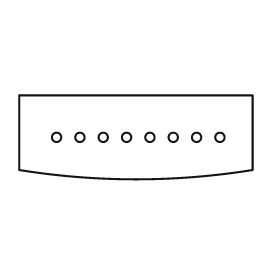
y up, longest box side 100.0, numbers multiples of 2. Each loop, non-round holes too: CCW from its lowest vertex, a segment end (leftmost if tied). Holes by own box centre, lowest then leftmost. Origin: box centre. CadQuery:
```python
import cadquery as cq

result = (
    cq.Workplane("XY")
    .moveTo(-50.0, -14.0)
    .threePointArc((0.0, -18.0), (50.0, -14.0))
    .lineTo(50.0, 18.0)
    .lineTo(-50.0, 18.0)
    .close()
    .moveTo(-34.0, 0.0)
    .circle(2.0)
    .moveTo(-24.0, 0.0)
    .circle(2.0)
    .moveTo(-14.0, 0.0)
    .circle(2.0)
    .moveTo(-4.0, 0.0)
    .circle(2.0)
    .moveTo(6.0, 0.0)
    .circle(2.0)
    .moveTo(16.0, 0.0)
    .circle(2.0)
    .moveTo(26.0, 0.0)
    .circle(2.0)
    .moveTo(36.0, 0.0)
    .circle(2.0)
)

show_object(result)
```